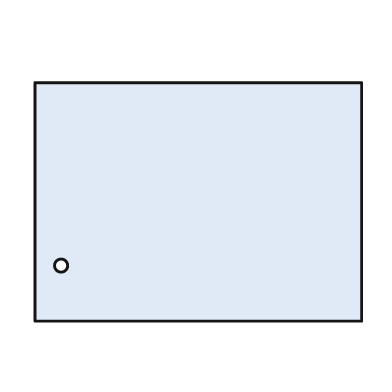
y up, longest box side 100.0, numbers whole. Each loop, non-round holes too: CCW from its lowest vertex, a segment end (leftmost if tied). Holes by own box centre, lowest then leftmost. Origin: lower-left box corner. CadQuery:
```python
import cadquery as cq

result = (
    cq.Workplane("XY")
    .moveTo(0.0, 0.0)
    .lineTo(100.0, 0.0)
    .lineTo(100.0, 73.0)
    .lineTo(0.0, 73.0)
    .close()
    .moveTo(8.0, 17.0)
    .circle(2.0)
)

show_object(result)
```